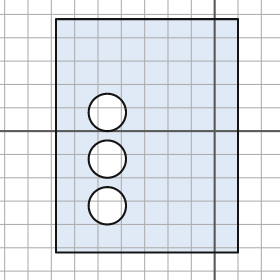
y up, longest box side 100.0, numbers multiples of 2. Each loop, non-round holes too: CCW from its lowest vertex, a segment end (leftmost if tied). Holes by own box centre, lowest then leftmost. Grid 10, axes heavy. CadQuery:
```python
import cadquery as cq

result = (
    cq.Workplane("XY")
    .moveTo(-68.0, -52.0)
    .lineTo(10.0, -52.0)
    .lineTo(10.0, 48.0)
    .lineTo(-68.0, 48.0)
    .close()
    .moveTo(-46.0, -32.0)
    .circle(8.0)
    .moveTo(-46.0, -12.0)
    .circle(8.0)
    .moveTo(-46.0, 8.0)
    .circle(8.0)
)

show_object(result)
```